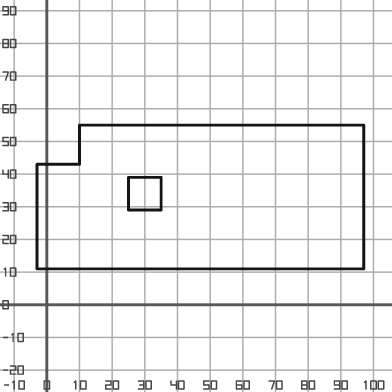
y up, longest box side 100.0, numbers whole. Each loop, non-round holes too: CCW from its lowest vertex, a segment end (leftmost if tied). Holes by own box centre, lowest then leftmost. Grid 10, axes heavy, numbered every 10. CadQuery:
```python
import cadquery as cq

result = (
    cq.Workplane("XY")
    .moveTo(-3.0, 11.0)
    .lineTo(97.0, 11.0)
    .lineTo(97.0, 55.0)
    .lineTo(10.0, 55.0)
    .lineTo(10.0, 43.0)
    .lineTo(-3.0, 43.0)
    .close()
    .moveTo(25.0, 29.0)
    .lineTo(35.0, 29.0)
    .lineTo(35.0, 39.0)
    .lineTo(25.0, 39.0)
    .close()
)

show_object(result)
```